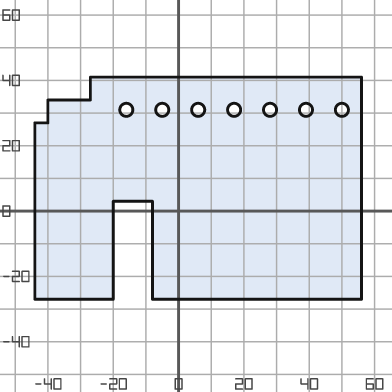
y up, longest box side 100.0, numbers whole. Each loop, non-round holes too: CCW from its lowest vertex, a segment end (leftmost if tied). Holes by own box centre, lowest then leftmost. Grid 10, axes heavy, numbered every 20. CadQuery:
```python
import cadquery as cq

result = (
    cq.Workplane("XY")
    .moveTo(-44.0, -27.0)
    .lineTo(-20.0, -27.0)
    .lineTo(-20.0, 3.0)
    .lineTo(-8.0, 3.0)
    .lineTo(-8.0, -27.0)
    .lineTo(56.0, -27.0)
    .lineTo(56.0, 41.0)
    .lineTo(-27.0, 41.0)
    .lineTo(-27.0, 34.0)
    .lineTo(-40.0, 34.0)
    .lineTo(-40.0, 27.0)
    .lineTo(-44.0, 27.0)
    .close()
    .moveTo(-16.0, 31.0)
    .circle(2.0)
    .moveTo(-5.0, 31.0)
    .circle(2.0)
    .moveTo(6.0, 31.0)
    .circle(2.0)
    .moveTo(17.0, 31.0)
    .circle(2.0)
    .moveTo(28.0, 31.0)
    .circle(2.0)
    .moveTo(39.0, 31.0)
    .circle(2.0)
    .moveTo(50.0, 31.0)
    .circle(2.0)
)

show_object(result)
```